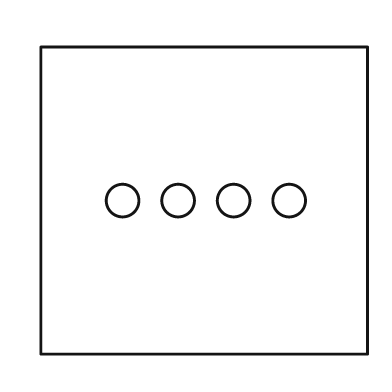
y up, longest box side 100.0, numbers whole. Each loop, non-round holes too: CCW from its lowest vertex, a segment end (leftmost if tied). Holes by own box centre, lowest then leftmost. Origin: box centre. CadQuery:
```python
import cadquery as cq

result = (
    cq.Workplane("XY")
    .moveTo(-50.0, -47.0)
    .lineTo(50.0, -47.0)
    .lineTo(50.0, 47.0)
    .lineTo(-50.0, 47.0)
    .close()
    .moveTo(-25.0, 0.0)
    .circle(5.0)
    .moveTo(-8.0, 0.0)
    .circle(5.0)
    .moveTo(9.0, 0.0)
    .circle(5.0)
    .moveTo(26.0, 0.0)
    .circle(5.0)
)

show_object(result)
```